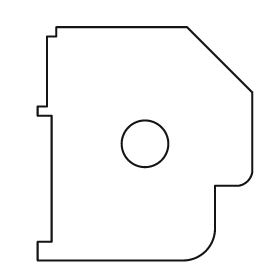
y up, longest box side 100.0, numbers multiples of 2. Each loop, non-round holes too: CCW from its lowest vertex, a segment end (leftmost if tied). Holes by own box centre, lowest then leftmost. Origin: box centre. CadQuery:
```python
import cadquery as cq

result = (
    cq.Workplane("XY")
    .moveTo(-46.0, -50.0)
    .lineTo(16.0, -50.0)
    .threePointArc((26.0, -46.0), (30.0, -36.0))
    .lineTo(30.0, -18.0)
    .lineTo(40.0, -18.0)
    .threePointArc((44.0, -16.0), (46.0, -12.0))
    .lineTo(46.0, 22.0)
    .lineTo(18.0, 50.0)
    .lineTo(-38.0, 50.0)
    .lineTo(-38.0, 46.0)
    .lineTo(-42.0, 46.0)
    .lineTo(-42.0, 16.0)
    .lineTo(-46.0, 16.0)
    .lineTo(-46.0, 12.0)
    .lineTo(-40.0, 12.0)
    .lineTo(-40.0, -42.0)
    .lineTo(-46.0, -42.0)
    .close()
    .moveTo(0.0, 0.0)
    .circle(10.0)
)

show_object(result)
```